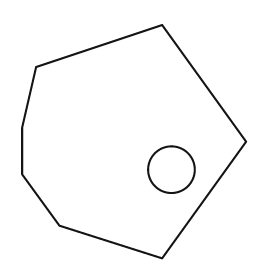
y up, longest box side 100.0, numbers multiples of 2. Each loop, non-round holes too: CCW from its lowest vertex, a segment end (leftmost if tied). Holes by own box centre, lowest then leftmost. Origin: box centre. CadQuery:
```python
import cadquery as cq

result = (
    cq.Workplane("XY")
    .moveTo(12.0, -50.0)
    .lineTo(48.0, 0.0)
    .lineTo(12.0, 50.0)
    .lineTo(-42.0, 32.0)
    .lineTo(-48.0, 6.0)
    .lineTo(-48.0, -14.0)
    .lineTo(-32.0, -36.0)
    .close()
    .moveTo(16.0, -12.0)
    .circle(10.0)
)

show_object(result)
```